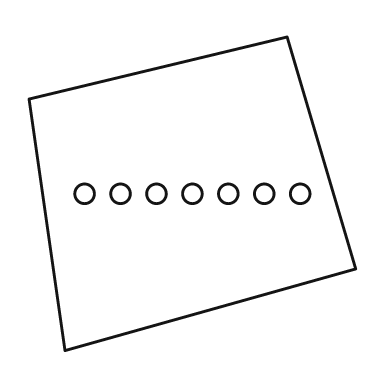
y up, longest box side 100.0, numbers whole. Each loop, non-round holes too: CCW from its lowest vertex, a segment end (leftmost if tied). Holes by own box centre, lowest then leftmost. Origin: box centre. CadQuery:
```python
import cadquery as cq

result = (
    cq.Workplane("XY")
    .moveTo(-39.0, -48.0)
    .lineTo(50.0, -23.0)
    .lineTo(29.0, 48.0)
    .lineTo(-50.0, 29.0)
    .close()
    .moveTo(-33.0, 0.0)
    .circle(3.0)
    .moveTo(-22.0, 0.0)
    .circle(3.0)
    .moveTo(-11.0, 0.0)
    .circle(3.0)
    .moveTo(0.0, 0.0)
    .circle(3.0)
    .moveTo(11.0, 0.0)
    .circle(3.0)
    .moveTo(22.0, 0.0)
    .circle(3.0)
    .moveTo(33.0, 0.0)
    .circle(3.0)
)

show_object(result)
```